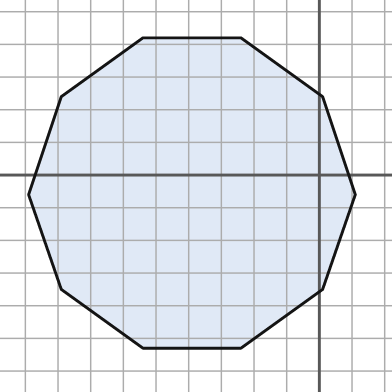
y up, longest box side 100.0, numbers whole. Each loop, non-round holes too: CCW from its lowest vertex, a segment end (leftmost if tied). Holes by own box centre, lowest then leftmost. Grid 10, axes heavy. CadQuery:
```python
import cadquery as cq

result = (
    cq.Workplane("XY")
    .moveTo(-54.0, -53.0)
    .lineTo(-24.0, -53.0)
    .lineTo(1.0, -35.0)
    .lineTo(11.0, -6.0)
    .lineTo(1.0, 24.0)
    .lineTo(-24.0, 42.0)
    .lineTo(-54.0, 42.0)
    .lineTo(-79.0, 24.0)
    .lineTo(-89.0, -6.0)
    .lineTo(-79.0, -35.0)
    .close()
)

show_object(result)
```